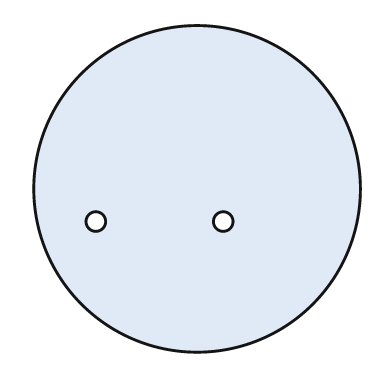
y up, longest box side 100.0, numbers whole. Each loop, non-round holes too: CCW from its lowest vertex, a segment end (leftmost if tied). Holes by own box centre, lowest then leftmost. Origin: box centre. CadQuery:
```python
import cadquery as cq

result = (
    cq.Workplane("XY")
    .moveTo(0.0, 0.0)
    .circle(50.0)
    .moveTo(-31.0, -10.0)
    .circle(3.0)
    .moveTo(8.0, -10.0)
    .circle(3.0)
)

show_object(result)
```